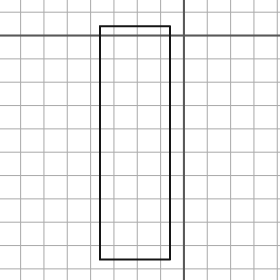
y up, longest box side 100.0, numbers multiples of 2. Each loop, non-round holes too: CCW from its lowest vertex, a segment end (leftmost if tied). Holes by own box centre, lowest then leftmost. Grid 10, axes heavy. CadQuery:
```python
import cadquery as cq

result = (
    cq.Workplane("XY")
    .moveTo(-36.0, -96.0)
    .lineTo(-6.0, -96.0)
    .lineTo(-6.0, 4.0)
    .lineTo(-36.0, 4.0)
    .close()
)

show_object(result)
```